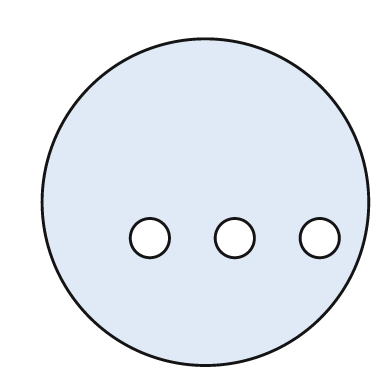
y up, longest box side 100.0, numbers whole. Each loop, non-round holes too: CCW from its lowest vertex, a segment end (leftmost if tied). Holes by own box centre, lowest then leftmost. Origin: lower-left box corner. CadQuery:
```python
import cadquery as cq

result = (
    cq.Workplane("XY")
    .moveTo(50.0, 50.0)
    .circle(50.0)
    .moveTo(33.0, 39.0)
    .circle(6.0)
    .moveTo(59.0, 39.0)
    .circle(6.0)
    .moveTo(85.0, 39.0)
    .circle(6.0)
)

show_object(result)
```